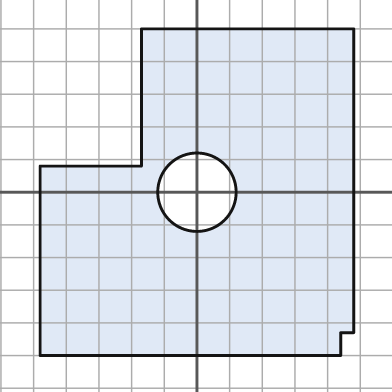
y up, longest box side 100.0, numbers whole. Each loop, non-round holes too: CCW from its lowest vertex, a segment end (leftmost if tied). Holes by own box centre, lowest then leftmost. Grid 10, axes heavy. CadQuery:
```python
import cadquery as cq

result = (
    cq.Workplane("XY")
    .moveTo(-48.0, -50.0)
    .lineTo(44.0, -50.0)
    .lineTo(44.0, -43.0)
    .lineTo(48.0, -43.0)
    .lineTo(48.0, 50.0)
    .lineTo(-17.0, 50.0)
    .lineTo(-17.0, 8.0)
    .lineTo(-48.0, 8.0)
    .close()
    .moveTo(0.0, 0.0)
    .circle(12.0)
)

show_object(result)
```